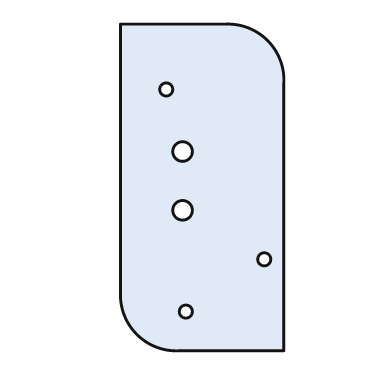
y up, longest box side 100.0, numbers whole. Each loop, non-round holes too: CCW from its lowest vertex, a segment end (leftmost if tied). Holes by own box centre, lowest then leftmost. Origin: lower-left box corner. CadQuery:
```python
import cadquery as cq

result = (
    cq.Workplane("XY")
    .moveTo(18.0, 0.0)
    .lineTo(50.0, 0.0)
    .lineTo(50.0, 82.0)
    .threePointArc((45.0, 95.0), (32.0, 100.0))
    .lineTo(0.0, 100.0)
    .lineTo(0.0, 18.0)
    .threePointArc((5.0, 5.0), (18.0, 0.0))
    .close()
    .moveTo(20.0, 12.0)
    .circle(2.0)
    .moveTo(44.0, 28.0)
    .circle(2.0)
    .moveTo(19.0, 43.0)
    .circle(3.0)
    .moveTo(19.0, 61.0)
    .circle(3.0)
    .moveTo(14.0, 80.0)
    .circle(2.0)
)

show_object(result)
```